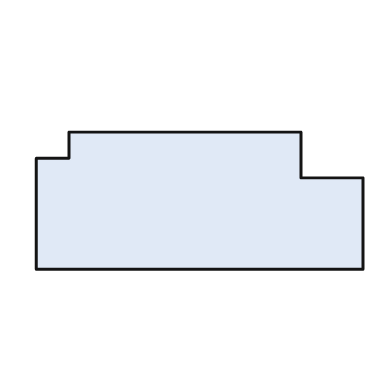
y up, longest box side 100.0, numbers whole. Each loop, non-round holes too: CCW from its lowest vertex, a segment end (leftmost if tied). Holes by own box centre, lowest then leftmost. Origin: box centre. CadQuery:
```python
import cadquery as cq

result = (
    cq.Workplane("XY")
    .moveTo(-50.0, -21.0)
    .lineTo(50.0, -21.0)
    .lineTo(50.0, 7.0)
    .lineTo(31.0, 7.0)
    .lineTo(31.0, 21.0)
    .lineTo(-40.0, 21.0)
    .lineTo(-40.0, 13.0)
    .lineTo(-50.0, 13.0)
    .close()
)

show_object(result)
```